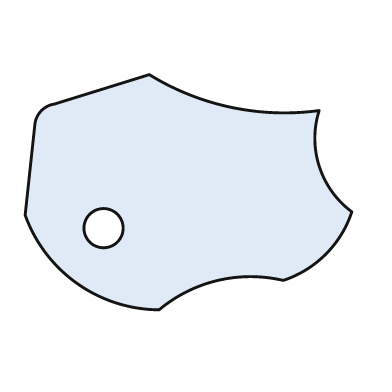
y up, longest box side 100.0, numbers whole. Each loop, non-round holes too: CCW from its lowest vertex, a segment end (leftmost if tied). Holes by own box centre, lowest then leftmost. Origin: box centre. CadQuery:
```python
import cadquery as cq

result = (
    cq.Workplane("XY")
    .moveTo(-9.0, -36.0)
    .threePointArc((9.0, -27.0), (29.0, -27.0))
    .threePointArc((42.0, -19.0), (50.0, -6.0))
    .threePointArc((40.0, 8.0), (40.0, 25.0))
    .threePointArc((13.0, 26.0), (-12.0, 36.0))
    .lineTo(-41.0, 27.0)
    .threePointArc((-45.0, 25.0), (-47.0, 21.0))
    .lineTo(-50.0, -7.0)
    .threePointArc((-34.0, -28.0), (-9.0, -36.0))
    .close()
    .moveTo(-26.0, -11.0)
    .circle(6.0)
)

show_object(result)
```